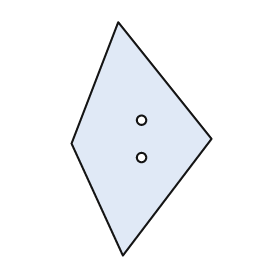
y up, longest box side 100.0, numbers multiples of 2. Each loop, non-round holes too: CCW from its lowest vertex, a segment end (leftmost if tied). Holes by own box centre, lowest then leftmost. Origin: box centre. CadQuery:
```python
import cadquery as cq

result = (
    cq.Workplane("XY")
    .moveTo(-8.0, -50.0)
    .lineTo(30.0, 0.0)
    .lineTo(-10.0, 50.0)
    .lineTo(-30.0, -2.0)
    .close()
    .moveTo(0.0, -8.0)
    .circle(2.0)
    .moveTo(0.0, 8.0)
    .circle(2.0)
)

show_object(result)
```